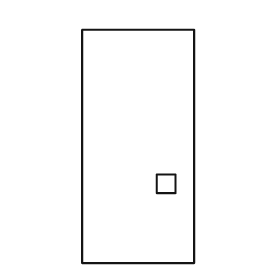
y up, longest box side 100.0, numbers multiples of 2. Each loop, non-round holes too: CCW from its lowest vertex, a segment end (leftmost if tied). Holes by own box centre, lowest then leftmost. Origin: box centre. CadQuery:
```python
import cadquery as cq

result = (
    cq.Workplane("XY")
    .moveTo(-24.0, -50.0)
    .lineTo(24.0, -50.0)
    .lineTo(24.0, 50.0)
    .lineTo(-24.0, 50.0)
    .close()
    .moveTo(8.0, -20.0)
    .lineTo(16.0, -20.0)
    .lineTo(16.0, -12.0)
    .lineTo(8.0, -12.0)
    .close()
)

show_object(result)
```